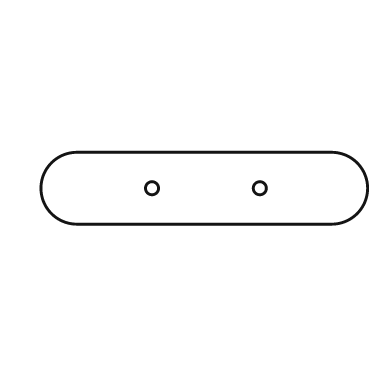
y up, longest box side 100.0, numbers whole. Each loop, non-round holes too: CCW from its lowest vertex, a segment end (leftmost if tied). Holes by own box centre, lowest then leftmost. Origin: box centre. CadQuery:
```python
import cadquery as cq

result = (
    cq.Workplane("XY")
    .moveTo(-39.0, -11.0)
    .lineTo(39.0, -11.0)
    .threePointArc((50.0, 0.0), (39.0, 11.0))
    .lineTo(-39.0, 11.0)
    .threePointArc((-50.0, 0.0), (-39.0, -11.0))
    .close()
    .moveTo(-16.0, 0.0)
    .circle(2.0)
    .moveTo(17.0, 0.0)
    .circle(2.0)
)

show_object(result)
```